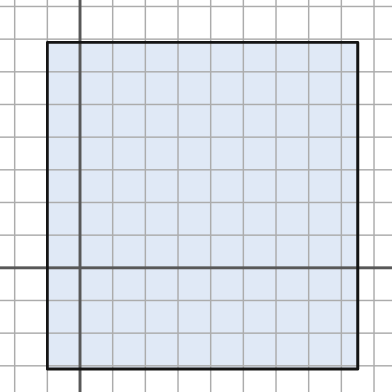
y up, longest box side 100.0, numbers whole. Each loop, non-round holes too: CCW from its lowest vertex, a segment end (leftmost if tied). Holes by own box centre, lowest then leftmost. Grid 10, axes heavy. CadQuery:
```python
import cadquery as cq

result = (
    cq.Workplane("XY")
    .moveTo(-10.0, -31.0)
    .lineTo(85.0, -31.0)
    .lineTo(85.0, 69.0)
    .lineTo(-10.0, 69.0)
    .close()
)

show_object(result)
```